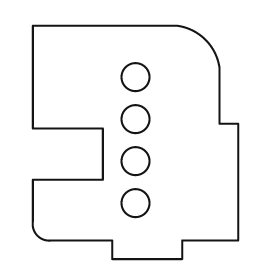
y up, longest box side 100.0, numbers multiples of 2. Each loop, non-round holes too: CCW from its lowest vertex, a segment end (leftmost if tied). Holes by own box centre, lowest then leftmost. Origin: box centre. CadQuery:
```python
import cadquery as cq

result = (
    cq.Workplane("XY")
    .moveTo(-10.0, -50.0)
    .lineTo(20.0, -50.0)
    .lineTo(20.0, -42.0)
    .lineTo(44.0, -42.0)
    .lineTo(44.0, 8.0)
    .lineTo(36.0, 8.0)
    .lineTo(36.0, 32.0)
    .threePointArc((30.0, 44.0), (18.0, 50.0))
    .lineTo(-44.0, 50.0)
    .lineTo(-44.0, 6.0)
    .lineTo(-14.0, 6.0)
    .lineTo(-14.0, -16.0)
    .lineTo(-44.0, -16.0)
    .lineTo(-44.0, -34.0)
    .threePointArc((-42.0, -40.0), (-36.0, -42.0))
    .lineTo(-10.0, -42.0)
    .close()
    .moveTo(0.0, -26.0)
    .circle(6.0)
    .moveTo(0.0, -8.0)
    .circle(6.0)
    .moveTo(0.0, 10.0)
    .circle(6.0)
    .moveTo(0.0, 28.0)
    .circle(6.0)
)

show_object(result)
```